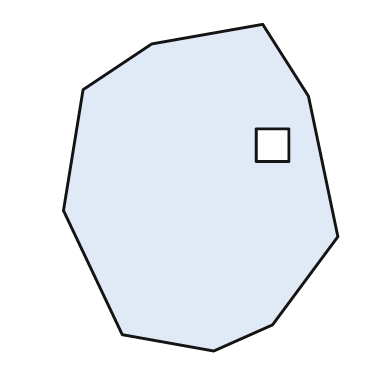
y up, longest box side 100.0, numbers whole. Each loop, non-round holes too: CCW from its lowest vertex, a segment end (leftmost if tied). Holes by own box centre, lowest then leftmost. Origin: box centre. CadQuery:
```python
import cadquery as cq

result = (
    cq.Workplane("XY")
    .moveTo(4.0, -50.0)
    .lineTo(22.0, -42.0)
    .lineTo(42.0, -15.0)
    .lineTo(33.0, 28.0)
    .lineTo(19.0, 50.0)
    .lineTo(-15.0, 44.0)
    .lineTo(-36.0, 30.0)
    .lineTo(-42.0, -7.0)
    .lineTo(-24.0, -45.0)
    .close()
    .moveTo(17.0, 8.0)
    .lineTo(27.0, 8.0)
    .lineTo(27.0, 18.0)
    .lineTo(17.0, 18.0)
    .close()
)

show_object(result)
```